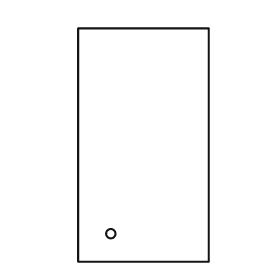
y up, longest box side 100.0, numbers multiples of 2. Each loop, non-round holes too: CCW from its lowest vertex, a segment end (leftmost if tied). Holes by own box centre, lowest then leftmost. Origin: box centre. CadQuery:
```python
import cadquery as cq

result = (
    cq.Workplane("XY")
    .moveTo(-28.0, -50.0)
    .lineTo(28.0, -50.0)
    .lineTo(28.0, 50.0)
    .lineTo(-28.0, 50.0)
    .close()
    .moveTo(-14.0, -38.0)
    .circle(2.0)
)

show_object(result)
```